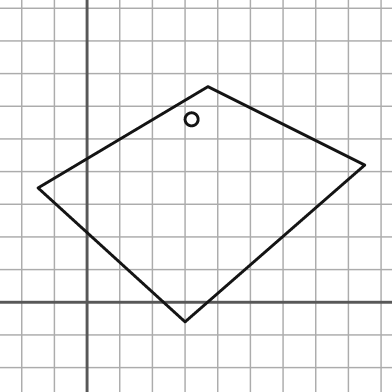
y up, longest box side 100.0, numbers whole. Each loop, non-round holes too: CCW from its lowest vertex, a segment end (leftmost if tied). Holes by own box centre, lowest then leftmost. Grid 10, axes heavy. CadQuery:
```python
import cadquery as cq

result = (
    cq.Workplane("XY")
    .moveTo(30.0, -6.0)
    .lineTo(85.0, 42.0)
    .lineTo(37.0, 66.0)
    .lineTo(-15.0, 35.0)
    .close()
    .moveTo(32.0, 56.0)
    .circle(2.0)
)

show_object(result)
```